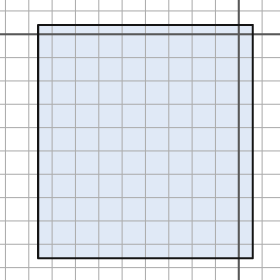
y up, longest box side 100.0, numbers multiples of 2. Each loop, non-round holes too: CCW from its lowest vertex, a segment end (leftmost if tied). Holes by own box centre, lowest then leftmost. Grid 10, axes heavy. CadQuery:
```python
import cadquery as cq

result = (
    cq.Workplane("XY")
    .moveTo(-86.0, -96.0)
    .lineTo(6.0, -96.0)
    .lineTo(6.0, 4.0)
    .lineTo(-86.0, 4.0)
    .close()
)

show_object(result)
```